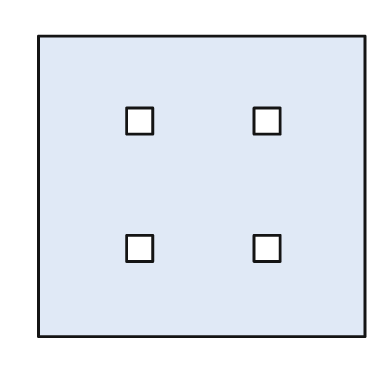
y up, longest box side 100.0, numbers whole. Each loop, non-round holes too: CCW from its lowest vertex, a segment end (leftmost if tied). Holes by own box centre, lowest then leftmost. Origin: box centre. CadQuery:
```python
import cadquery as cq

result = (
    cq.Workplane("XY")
    .moveTo(-50.0, -46.0)
    .lineTo(50.0, -46.0)
    .lineTo(50.0, 46.0)
    .lineTo(-50.0, 46.0)
    .close()
    .moveTo(-23.0, -23.0)
    .lineTo(-15.0, -23.0)
    .lineTo(-15.0, -15.0)
    .lineTo(-23.0, -15.0)
    .close()
    .moveTo(16.0, -23.0)
    .lineTo(24.0, -23.0)
    .lineTo(24.0, -15.0)
    .lineTo(16.0, -15.0)
    .close()
    .moveTo(-23.0, 16.0)
    .lineTo(-15.0, 16.0)
    .lineTo(-15.0, 24.0)
    .lineTo(-23.0, 24.0)
    .close()
    .moveTo(16.0, 16.0)
    .lineTo(24.0, 16.0)
    .lineTo(24.0, 24.0)
    .lineTo(16.0, 24.0)
    .close()
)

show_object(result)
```